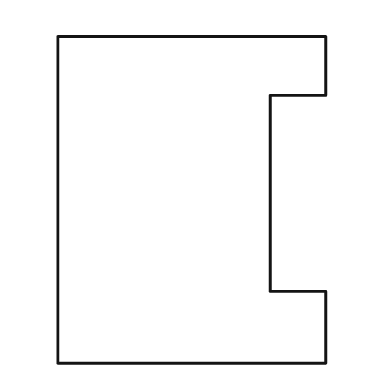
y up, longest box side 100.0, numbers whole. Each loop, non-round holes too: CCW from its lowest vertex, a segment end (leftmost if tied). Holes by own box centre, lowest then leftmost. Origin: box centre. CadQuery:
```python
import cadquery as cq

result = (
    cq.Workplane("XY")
    .moveTo(-41.0, -50.0)
    .lineTo(41.0, -50.0)
    .lineTo(41.0, -28.0)
    .lineTo(24.0, -28.0)
    .lineTo(24.0, 32.0)
    .lineTo(41.0, 32.0)
    .lineTo(41.0, 50.0)
    .lineTo(-41.0, 50.0)
    .close()
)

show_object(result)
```